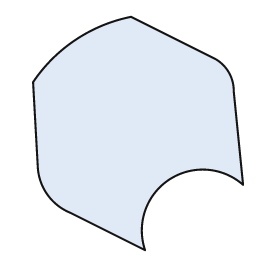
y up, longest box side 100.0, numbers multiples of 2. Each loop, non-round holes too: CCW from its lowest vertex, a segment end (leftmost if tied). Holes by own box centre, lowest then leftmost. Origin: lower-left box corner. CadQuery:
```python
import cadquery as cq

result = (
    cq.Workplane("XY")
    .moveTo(48.0, 0.0)
    .threePointArc((58.0, 30.0), (90.0, 28.0))
    .lineTo(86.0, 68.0)
    .threePointArc((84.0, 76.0), (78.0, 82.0))
    .lineTo(42.0, 100.0)
    .threePointArc((18.0, 90.0), (0.0, 72.0))
    .lineTo(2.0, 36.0)
    .threePointArc((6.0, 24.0), (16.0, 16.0))
    .close()
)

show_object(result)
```